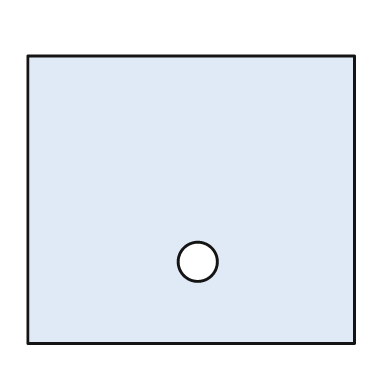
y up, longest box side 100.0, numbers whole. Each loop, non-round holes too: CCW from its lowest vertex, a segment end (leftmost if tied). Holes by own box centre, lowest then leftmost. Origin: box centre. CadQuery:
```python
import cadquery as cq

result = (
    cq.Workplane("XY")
    .moveTo(-50.0, -44.0)
    .lineTo(50.0, -44.0)
    .lineTo(50.0, 44.0)
    .lineTo(-50.0, 44.0)
    .close()
    .moveTo(2.0, -19.0)
    .circle(6.0)
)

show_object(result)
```